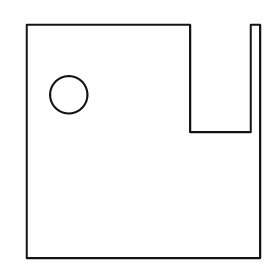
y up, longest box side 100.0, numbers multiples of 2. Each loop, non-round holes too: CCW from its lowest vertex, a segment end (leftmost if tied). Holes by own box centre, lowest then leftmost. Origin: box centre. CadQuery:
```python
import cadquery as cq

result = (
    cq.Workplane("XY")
    .moveTo(-50.0, -50.0)
    .lineTo(50.0, -50.0)
    .lineTo(50.0, 50.0)
    .lineTo(46.0, 50.0)
    .lineTo(46.0, 4.0)
    .lineTo(20.0, 4.0)
    .lineTo(20.0, 50.0)
    .lineTo(-50.0, 50.0)
    .close()
    .moveTo(-32.0, 20.0)
    .circle(8.0)
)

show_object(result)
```